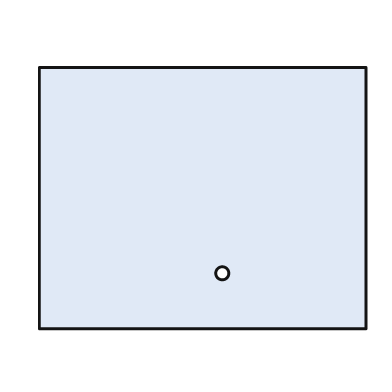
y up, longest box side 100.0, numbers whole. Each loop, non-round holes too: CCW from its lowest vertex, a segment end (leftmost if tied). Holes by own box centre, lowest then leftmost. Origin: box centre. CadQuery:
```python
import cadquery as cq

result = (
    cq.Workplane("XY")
    .moveTo(-50.0, -40.0)
    .lineTo(50.0, -40.0)
    .lineTo(50.0, 40.0)
    .lineTo(-50.0, 40.0)
    .close()
    .moveTo(6.0, -23.0)
    .circle(2.0)
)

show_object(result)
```